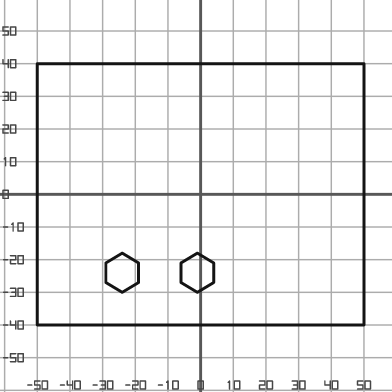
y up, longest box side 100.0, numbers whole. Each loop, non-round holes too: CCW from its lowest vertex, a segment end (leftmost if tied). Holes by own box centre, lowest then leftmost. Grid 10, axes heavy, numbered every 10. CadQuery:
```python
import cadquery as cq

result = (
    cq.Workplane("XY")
    .moveTo(-50.0, -40.0)
    .lineTo(50.0, -40.0)
    .lineTo(50.0, 40.0)
    .lineTo(-50.0, 40.0)
    .close()
    .moveTo(-24.0, -30.0)
    .lineTo(-19.0, -27.0)
    .lineTo(-19.0, -21.0)
    .lineTo(-24.0, -18.0)
    .lineTo(-29.0, -21.0)
    .lineTo(-29.0, -27.0)
    .close()
    .moveTo(-1.0, -30.0)
    .lineTo(4.0, -27.0)
    .lineTo(4.0, -21.0)
    .lineTo(-1.0, -18.0)
    .lineTo(-6.0, -21.0)
    .lineTo(-6.0, -27.0)
    .close()
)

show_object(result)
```